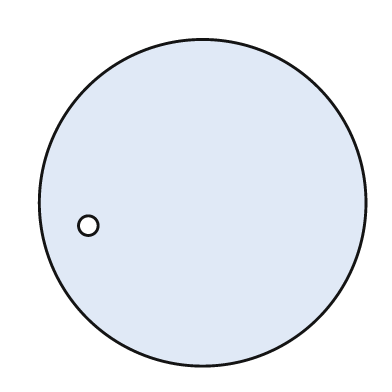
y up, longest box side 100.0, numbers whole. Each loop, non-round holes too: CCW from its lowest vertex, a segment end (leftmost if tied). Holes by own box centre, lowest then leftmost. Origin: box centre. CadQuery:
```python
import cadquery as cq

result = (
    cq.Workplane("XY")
    .moveTo(0.0, 0.0)
    .circle(50.0)
    .moveTo(-35.0, -7.0)
    .circle(3.0)
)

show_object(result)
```